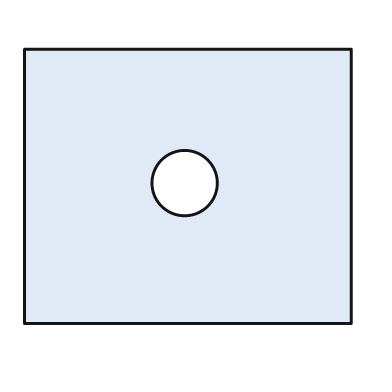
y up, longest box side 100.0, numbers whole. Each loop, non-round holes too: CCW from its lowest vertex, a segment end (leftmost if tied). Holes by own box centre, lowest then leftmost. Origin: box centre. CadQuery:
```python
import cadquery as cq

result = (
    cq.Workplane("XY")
    .moveTo(-50.0, -42.0)
    .lineTo(50.0, -42.0)
    .lineTo(50.0, 42.0)
    .lineTo(-50.0, 42.0)
    .close()
    .moveTo(-1.0, 1.0)
    .circle(10.0)
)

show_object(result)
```